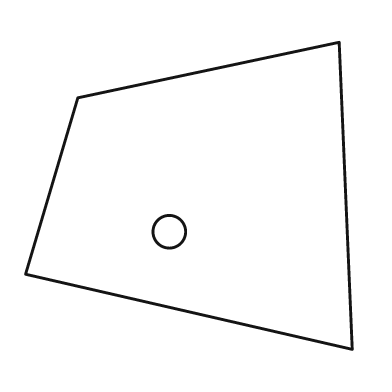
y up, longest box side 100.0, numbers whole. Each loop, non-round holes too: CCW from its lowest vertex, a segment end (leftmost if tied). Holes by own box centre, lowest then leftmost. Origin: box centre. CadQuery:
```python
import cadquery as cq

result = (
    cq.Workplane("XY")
    .moveTo(50.0, -47.0)
    .lineTo(46.0, 47.0)
    .lineTo(-34.0, 30.0)
    .lineTo(-50.0, -24.0)
    .close()
    .moveTo(-6.0, -11.0)
    .circle(5.0)
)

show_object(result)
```